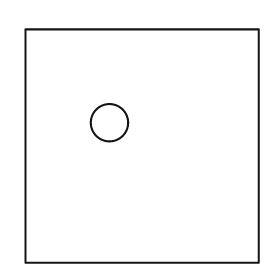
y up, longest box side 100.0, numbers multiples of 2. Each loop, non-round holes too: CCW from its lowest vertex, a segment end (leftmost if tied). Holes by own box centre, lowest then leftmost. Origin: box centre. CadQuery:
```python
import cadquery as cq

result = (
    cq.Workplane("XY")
    .moveTo(-50.0, -50.0)
    .lineTo(50.0, -50.0)
    .lineTo(50.0, 50.0)
    .lineTo(-50.0, 50.0)
    .close()
    .moveTo(-14.0, 10.0)
    .circle(8.0)
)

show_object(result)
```